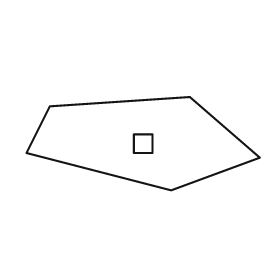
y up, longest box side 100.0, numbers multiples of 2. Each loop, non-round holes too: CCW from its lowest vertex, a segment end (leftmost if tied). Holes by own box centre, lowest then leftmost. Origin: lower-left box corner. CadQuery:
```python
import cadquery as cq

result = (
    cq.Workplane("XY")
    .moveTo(62.0, 0.0)
    .lineTo(100.0, 14.0)
    .lineTo(70.0, 40.0)
    .lineTo(10.0, 36.0)
    .lineTo(0.0, 16.0)
    .close()
    .moveTo(46.0, 16.0)
    .lineTo(54.0, 16.0)
    .lineTo(54.0, 24.0)
    .lineTo(46.0, 24.0)
    .close()
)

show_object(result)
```